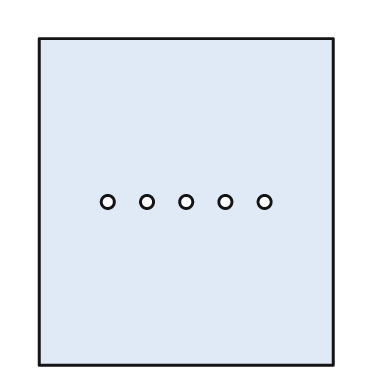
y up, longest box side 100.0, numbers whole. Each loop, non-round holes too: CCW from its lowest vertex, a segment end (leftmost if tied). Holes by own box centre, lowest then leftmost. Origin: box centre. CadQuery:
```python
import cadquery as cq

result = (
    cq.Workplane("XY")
    .moveTo(-45.0, -50.0)
    .lineTo(45.0, -50.0)
    .lineTo(45.0, 50.0)
    .lineTo(-45.0, 50.0)
    .close()
    .moveTo(-24.0, 0.0)
    .circle(2.0)
    .moveTo(-12.0, 0.0)
    .circle(2.0)
    .moveTo(0.0, 0.0)
    .circle(2.0)
    .moveTo(12.0, 0.0)
    .circle(2.0)
    .moveTo(24.0, 0.0)
    .circle(2.0)
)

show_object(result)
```